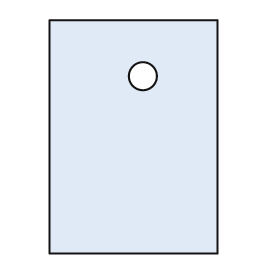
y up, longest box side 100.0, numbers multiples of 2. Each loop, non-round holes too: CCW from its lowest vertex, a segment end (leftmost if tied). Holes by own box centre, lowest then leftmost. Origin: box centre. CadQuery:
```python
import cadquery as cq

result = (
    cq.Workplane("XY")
    .moveTo(-36.0, -50.0)
    .lineTo(36.0, -50.0)
    .lineTo(36.0, 50.0)
    .lineTo(-36.0, 50.0)
    .close()
    .moveTo(4.0, 26.0)
    .circle(6.0)
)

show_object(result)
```